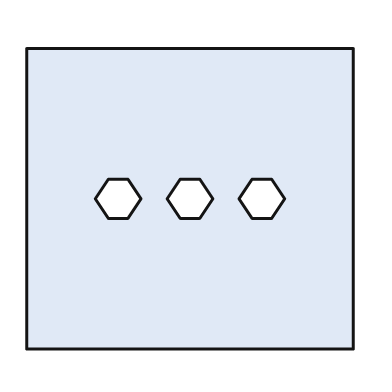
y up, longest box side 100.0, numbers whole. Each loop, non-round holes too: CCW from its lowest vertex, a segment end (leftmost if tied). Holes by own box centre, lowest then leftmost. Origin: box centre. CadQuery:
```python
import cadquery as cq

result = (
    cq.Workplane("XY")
    .moveTo(-50.0, -46.0)
    .lineTo(50.0, -46.0)
    .lineTo(50.0, 46.0)
    .lineTo(-50.0, 46.0)
    .close()
    .moveTo(-25.0, -6.0)
    .lineTo(-19.0, -6.0)
    .lineTo(-15.0, 0.0)
    .lineTo(-19.0, 6.0)
    .lineTo(-25.0, 6.0)
    .lineTo(-29.0, 0.0)
    .close()
    .moveTo(-3.0, -6.0)
    .lineTo(3.0, -6.0)
    .lineTo(7.0, 0.0)
    .lineTo(3.0, 6.0)
    .lineTo(-3.0, 6.0)
    .lineTo(-7.0, 0.0)
    .close()
    .moveTo(19.0, -6.0)
    .lineTo(25.0, -6.0)
    .lineTo(29.0, 0.0)
    .lineTo(25.0, 6.0)
    .lineTo(19.0, 6.0)
    .lineTo(15.0, 0.0)
    .close()
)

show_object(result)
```